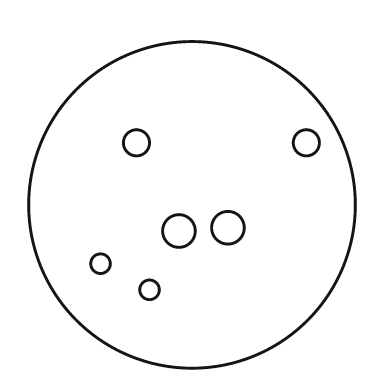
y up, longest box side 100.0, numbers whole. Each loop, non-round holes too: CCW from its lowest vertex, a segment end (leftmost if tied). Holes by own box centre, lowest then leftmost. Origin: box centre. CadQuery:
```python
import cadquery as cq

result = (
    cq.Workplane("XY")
    .moveTo(0.0, 0.0)
    .circle(50.0)
    .moveTo(-13.0, -26.0)
    .circle(3.0)
    .moveTo(-28.0, -18.0)
    .circle(3.0)
    .moveTo(-4.0, -8.0)
    .circle(5.0)
    .moveTo(11.0, -7.0)
    .circle(5.0)
    .moveTo(-17.0, 19.0)
    .circle(4.0)
    .moveTo(35.0, 19.0)
    .circle(4.0)
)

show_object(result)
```